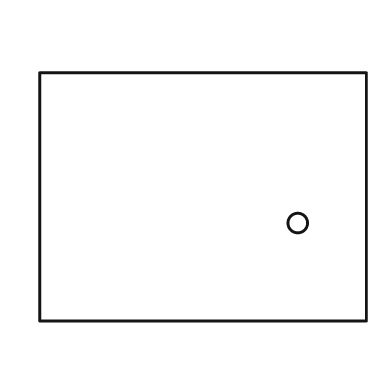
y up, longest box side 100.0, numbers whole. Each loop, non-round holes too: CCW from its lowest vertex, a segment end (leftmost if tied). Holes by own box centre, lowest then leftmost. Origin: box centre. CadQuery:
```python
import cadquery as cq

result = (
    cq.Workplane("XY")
    .moveTo(-50.0, -38.0)
    .lineTo(50.0, -38.0)
    .lineTo(50.0, 38.0)
    .lineTo(-50.0, 38.0)
    .close()
    .moveTo(29.0, -8.0)
    .circle(3.0)
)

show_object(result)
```